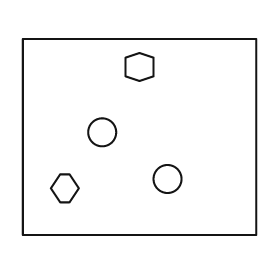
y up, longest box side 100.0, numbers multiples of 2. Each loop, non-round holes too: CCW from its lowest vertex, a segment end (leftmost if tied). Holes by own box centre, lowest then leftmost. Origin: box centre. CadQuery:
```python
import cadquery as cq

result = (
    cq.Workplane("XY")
    .moveTo(-50.0, -42.0)
    .lineTo(50.0, -42.0)
    .lineTo(50.0, 42.0)
    .lineTo(-50.0, 42.0)
    .close()
    .moveTo(-34.0, -28.0)
    .lineTo(-30.0, -28.0)
    .lineTo(-26.0, -22.0)
    .lineTo(-30.0, -16.0)
    .lineTo(-34.0, -16.0)
    .lineTo(-38.0, -22.0)
    .close()
    .moveTo(12.0, -18.0)
    .circle(6.0)
    .moveTo(-16.0, 2.0)
    .circle(6.0)
    .moveTo(0.0, 24.0)
    .lineTo(6.0, 26.0)
    .lineTo(6.0, 34.0)
    .lineTo(0.0, 36.0)
    .lineTo(-6.0, 34.0)
    .lineTo(-6.0, 26.0)
    .close()
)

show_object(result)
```